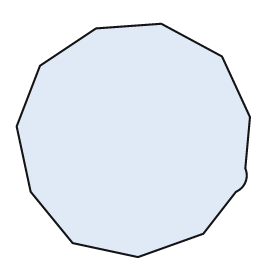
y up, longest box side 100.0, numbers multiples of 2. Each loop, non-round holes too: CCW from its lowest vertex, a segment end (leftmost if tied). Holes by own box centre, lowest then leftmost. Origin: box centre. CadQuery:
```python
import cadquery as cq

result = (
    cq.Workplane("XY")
    .moveTo(2.0, -50.0)
    .lineTo(30.0, -40.0)
    .lineTo(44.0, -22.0)
    .threePointArc((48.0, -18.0), (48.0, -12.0))
    .lineTo(50.0, 10.0)
    .lineTo(38.0, 36.0)
    .lineTo(12.0, 50.0)
    .lineTo(-16.0, 48.0)
    .lineTo(-40.0, 32.0)
    .lineTo(-50.0, 6.0)
    .lineTo(-44.0, -22.0)
    .lineTo(-26.0, -44.0)
    .close()
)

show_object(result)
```